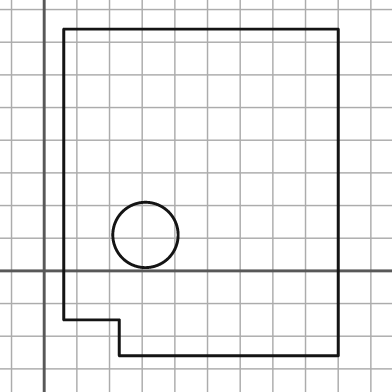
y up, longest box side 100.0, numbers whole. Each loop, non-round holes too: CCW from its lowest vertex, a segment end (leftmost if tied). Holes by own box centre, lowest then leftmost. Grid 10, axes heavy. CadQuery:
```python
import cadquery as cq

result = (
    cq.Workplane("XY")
    .moveTo(23.0, -26.0)
    .lineTo(90.0, -26.0)
    .lineTo(90.0, 74.0)
    .lineTo(6.0, 74.0)
    .lineTo(6.0, -15.0)
    .lineTo(23.0, -15.0)
    .close()
    .moveTo(31.0, 11.0)
    .circle(10.0)
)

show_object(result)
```